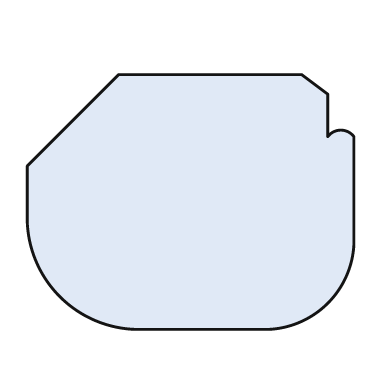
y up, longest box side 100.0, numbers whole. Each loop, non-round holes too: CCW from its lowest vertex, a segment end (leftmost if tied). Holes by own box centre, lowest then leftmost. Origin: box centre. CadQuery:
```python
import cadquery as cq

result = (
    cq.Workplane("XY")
    .moveTo(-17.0, -39.0)
    .lineTo(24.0, -39.0)
    .threePointArc((42.0, -31.0), (50.0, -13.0))
    .lineTo(50.0, 20.0)
    .threePointArc((46.0, 22.0), (42.0, 20.0))
    .lineTo(42.0, 33.0)
    .lineTo(34.0, 39.0)
    .lineTo(-22.0, 39.0)
    .lineTo(-50.0, 11.0)
    .lineTo(-50.0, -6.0)
    .threePointArc((-40.0, -29.0), (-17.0, -39.0))
    .close()
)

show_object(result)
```